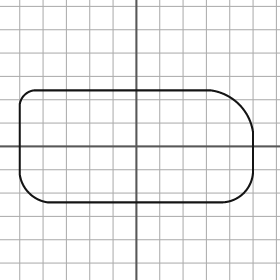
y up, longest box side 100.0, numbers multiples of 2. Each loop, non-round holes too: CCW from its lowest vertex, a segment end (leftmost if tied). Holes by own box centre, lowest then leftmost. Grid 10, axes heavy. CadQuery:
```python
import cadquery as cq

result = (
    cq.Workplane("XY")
    .moveTo(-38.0, -24.0)
    .lineTo(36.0, -24.0)
    .threePointArc((46.0, -20.0), (50.0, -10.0))
    .lineTo(50.0, 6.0)
    .threePointArc((44.0, 18.0), (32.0, 24.0))
    .lineTo(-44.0, 24.0)
    .threePointArc((-48.0, 22.0), (-50.0, 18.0))
    .lineTo(-50.0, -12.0)
    .threePointArc((-46.0, -20.0), (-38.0, -24.0))
    .close()
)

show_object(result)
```